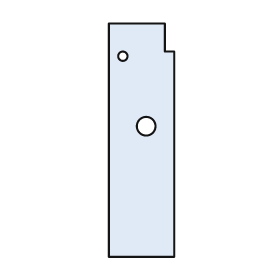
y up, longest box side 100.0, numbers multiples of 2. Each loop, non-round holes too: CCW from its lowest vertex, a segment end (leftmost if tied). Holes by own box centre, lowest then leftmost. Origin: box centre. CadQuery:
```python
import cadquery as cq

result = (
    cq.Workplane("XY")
    .moveTo(-14.0, -50.0)
    .lineTo(14.0, -50.0)
    .lineTo(14.0, 38.0)
    .lineTo(10.0, 38.0)
    .lineTo(10.0, 50.0)
    .lineTo(-14.0, 50.0)
    .close()
    .moveTo(2.0, 6.0)
    .circle(4.0)
    .moveTo(-8.0, 36.0)
    .circle(2.0)
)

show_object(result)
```